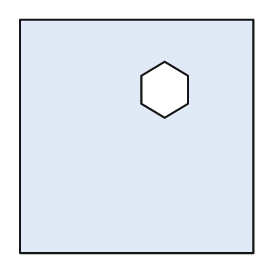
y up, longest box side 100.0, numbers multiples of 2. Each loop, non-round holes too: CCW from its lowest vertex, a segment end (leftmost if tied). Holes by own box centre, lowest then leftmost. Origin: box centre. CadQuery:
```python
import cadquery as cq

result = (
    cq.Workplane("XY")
    .moveTo(-50.0, -50.0)
    .lineTo(50.0, -50.0)
    .lineTo(50.0, 50.0)
    .lineTo(-50.0, 50.0)
    .close()
    .moveTo(12.0, 8.0)
    .lineTo(22.0, 14.0)
    .lineTo(22.0, 26.0)
    .lineTo(12.0, 32.0)
    .lineTo(2.0, 26.0)
    .lineTo(2.0, 14.0)
    .close()
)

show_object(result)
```